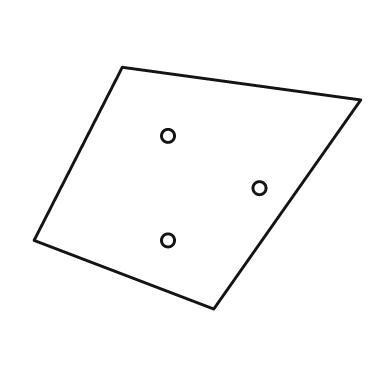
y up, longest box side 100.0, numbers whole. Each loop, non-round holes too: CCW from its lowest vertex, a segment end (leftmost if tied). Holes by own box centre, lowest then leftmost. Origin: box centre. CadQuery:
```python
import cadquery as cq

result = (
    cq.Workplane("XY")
    .moveTo(5.0, -37.0)
    .lineTo(50.0, 27.0)
    .lineTo(-23.0, 37.0)
    .lineTo(-50.0, -16.0)
    .close()
    .moveTo(-9.0, -16.0)
    .circle(2.0)
    .moveTo(19.0, 0.0)
    .circle(2.0)
    .moveTo(-9.0, 16.0)
    .circle(2.0)
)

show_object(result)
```